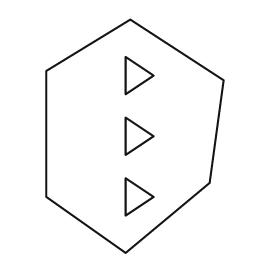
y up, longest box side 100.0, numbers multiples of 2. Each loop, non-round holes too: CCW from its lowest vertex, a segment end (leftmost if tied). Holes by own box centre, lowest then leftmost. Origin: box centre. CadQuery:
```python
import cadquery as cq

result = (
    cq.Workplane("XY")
    .moveTo(-4.0, -50.0)
    .lineTo(32.0, -20.0)
    .lineTo(38.0, 24.0)
    .lineTo(-2.0, 50.0)
    .lineTo(-38.0, 28.0)
    .lineTo(-38.0, -26.0)
    .close()
    .moveTo(-4.0, -34.0)
    .lineTo(8.0, -26.0)
    .lineTo(-4.0, -18.0)
    .close()
    .moveTo(-4.0, -8.0)
    .lineTo(8.0, 0.0)
    .lineTo(-4.0, 8.0)
    .close()
    .moveTo(-4.0, 18.0)
    .lineTo(8.0, 26.0)
    .lineTo(-4.0, 34.0)
    .close()
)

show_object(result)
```